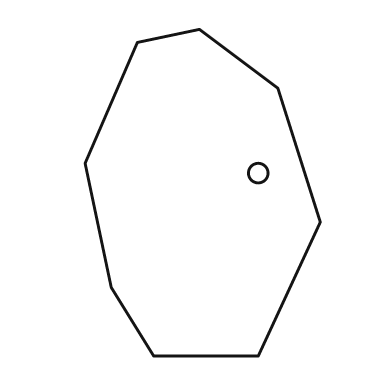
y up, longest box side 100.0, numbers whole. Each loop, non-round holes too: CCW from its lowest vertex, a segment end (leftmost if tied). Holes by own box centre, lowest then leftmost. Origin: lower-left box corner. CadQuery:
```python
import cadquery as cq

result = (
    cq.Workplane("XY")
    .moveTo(21.0, 0.0)
    .lineTo(53.0, 0.0)
    .lineTo(72.0, 41.0)
    .lineTo(59.0, 82.0)
    .lineTo(35.0, 100.0)
    .lineTo(16.0, 96.0)
    .lineTo(0.0, 59.0)
    .lineTo(8.0, 21.0)
    .close()
    .moveTo(53.0, 56.0)
    .circle(3.0)
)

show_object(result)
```